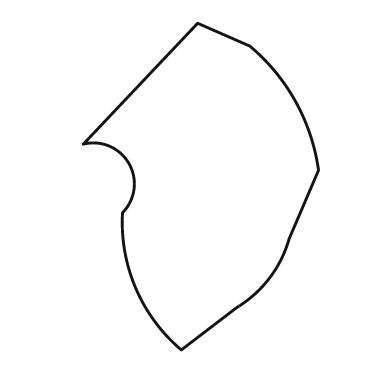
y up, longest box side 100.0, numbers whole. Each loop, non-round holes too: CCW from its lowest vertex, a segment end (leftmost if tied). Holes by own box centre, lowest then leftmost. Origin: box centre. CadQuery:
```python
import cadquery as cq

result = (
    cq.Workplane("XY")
    .moveTo(-6.0, -50.0)
    .lineTo(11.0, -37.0)
    .threePointArc((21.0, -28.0), (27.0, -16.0))
    .lineTo(36.0, 5.0)
    .threePointArc((29.0, 26.0), (15.0, 43.0))
    .lineTo(-1.0, 50.0)
    .lineTo(-36.0, 13.0)
    .threePointArc((-22.0, 7.0), (-24.0, -8.0))
    .threePointArc((-20.0, -31.0), (-6.0, -50.0))
    .close()
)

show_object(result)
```